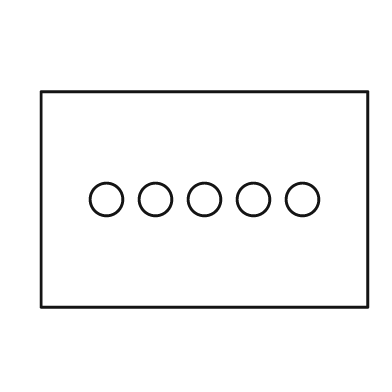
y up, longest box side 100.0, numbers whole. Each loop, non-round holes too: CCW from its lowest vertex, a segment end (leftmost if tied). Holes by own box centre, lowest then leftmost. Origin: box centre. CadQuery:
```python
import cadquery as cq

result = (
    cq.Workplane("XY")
    .moveTo(-50.0, -33.0)
    .lineTo(50.0, -33.0)
    .lineTo(50.0, 33.0)
    .lineTo(-50.0, 33.0)
    .close()
    .moveTo(-30.0, 0.0)
    .circle(5.0)
    .moveTo(-15.0, 0.0)
    .circle(5.0)
    .moveTo(0.0, 0.0)
    .circle(5.0)
    .moveTo(15.0, 0.0)
    .circle(5.0)
    .moveTo(30.0, 0.0)
    .circle(5.0)
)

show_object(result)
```